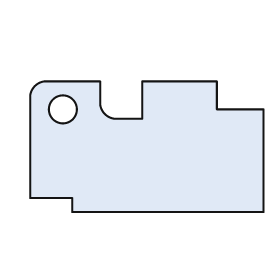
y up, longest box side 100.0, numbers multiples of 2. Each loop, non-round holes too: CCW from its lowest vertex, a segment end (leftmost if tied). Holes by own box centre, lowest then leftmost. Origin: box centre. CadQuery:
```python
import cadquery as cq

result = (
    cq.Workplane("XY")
    .moveTo(-32.0, -28.0)
    .lineTo(50.0, -28.0)
    .lineTo(50.0, 16.0)
    .lineTo(30.0, 16.0)
    .lineTo(30.0, 28.0)
    .lineTo(-2.0, 28.0)
    .lineTo(-2.0, 12.0)
    .lineTo(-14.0, 12.0)
    .threePointArc((-18.0, 14.0), (-20.0, 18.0))
    .lineTo(-20.0, 28.0)
    .lineTo(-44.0, 28.0)
    .threePointArc((-48.0, 26.0), (-50.0, 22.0))
    .lineTo(-50.0, -22.0)
    .lineTo(-32.0, -22.0)
    .close()
    .moveTo(-36.0, 16.0)
    .circle(6.0)
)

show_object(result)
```